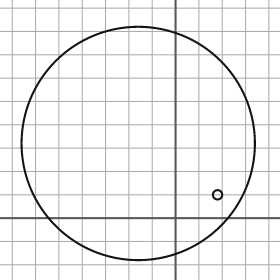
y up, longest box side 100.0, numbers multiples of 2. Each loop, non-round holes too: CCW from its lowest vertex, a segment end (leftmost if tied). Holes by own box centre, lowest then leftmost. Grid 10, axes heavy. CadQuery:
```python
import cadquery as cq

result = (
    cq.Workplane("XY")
    .moveTo(-16.0, 32.0)
    .circle(50.0)
    .moveTo(18.0, 10.0)
    .circle(2.0)
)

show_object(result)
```